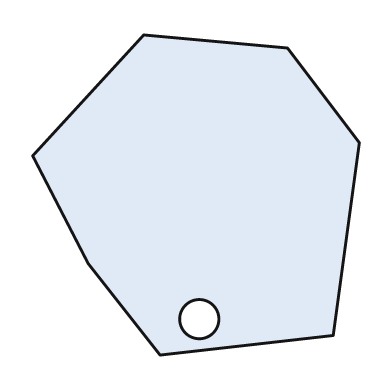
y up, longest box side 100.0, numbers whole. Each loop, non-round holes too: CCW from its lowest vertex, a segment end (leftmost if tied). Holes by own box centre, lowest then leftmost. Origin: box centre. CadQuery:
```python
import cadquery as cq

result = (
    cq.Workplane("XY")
    .moveTo(-11.0, -49.0)
    .lineTo(42.0, -43.0)
    .lineTo(50.0, 16.0)
    .lineTo(28.0, 45.0)
    .lineTo(-16.0, 49.0)
    .lineTo(-50.0, 12.0)
    .lineTo(-33.0, -21.0)
    .close()
    .moveTo(1.0, -38.0)
    .circle(6.0)
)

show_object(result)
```